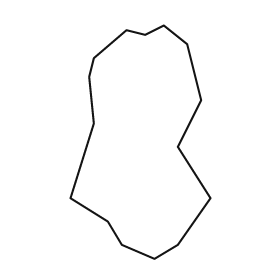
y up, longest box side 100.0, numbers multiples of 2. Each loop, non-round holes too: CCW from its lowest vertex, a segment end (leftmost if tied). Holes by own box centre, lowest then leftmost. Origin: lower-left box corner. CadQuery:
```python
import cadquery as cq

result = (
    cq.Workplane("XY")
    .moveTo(36.0, 0.0)
    .lineTo(46.0, 6.0)
    .lineTo(60.0, 26.0)
    .lineTo(46.0, 48.0)
    .lineTo(56.0, 68.0)
    .lineTo(50.0, 92.0)
    .lineTo(40.0, 100.0)
    .lineTo(32.0, 96.0)
    .lineTo(24.0, 98.0)
    .lineTo(10.0, 86.0)
    .lineTo(8.0, 78.0)
    .lineTo(10.0, 58.0)
    .lineTo(0.0, 26.0)
    .lineTo(16.0, 16.0)
    .lineTo(22.0, 6.0)
    .close()
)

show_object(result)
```